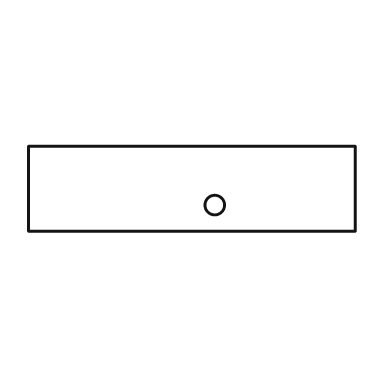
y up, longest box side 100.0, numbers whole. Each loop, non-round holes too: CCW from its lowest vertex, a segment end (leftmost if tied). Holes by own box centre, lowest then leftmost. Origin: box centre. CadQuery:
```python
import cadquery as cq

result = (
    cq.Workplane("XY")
    .moveTo(-50.0, -13.0)
    .lineTo(50.0, -13.0)
    .lineTo(50.0, 13.0)
    .lineTo(-50.0, 13.0)
    .close()
    .moveTo(7.0, -5.0)
    .circle(3.0)
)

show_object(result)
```